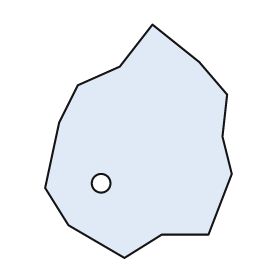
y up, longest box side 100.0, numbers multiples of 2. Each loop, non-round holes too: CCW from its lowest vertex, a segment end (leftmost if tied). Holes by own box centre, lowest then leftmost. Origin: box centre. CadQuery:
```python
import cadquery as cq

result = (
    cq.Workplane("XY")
    .moveTo(-6.0, -50.0)
    .lineTo(10.0, -40.0)
    .lineTo(30.0, -40.0)
    .lineTo(40.0, -14.0)
    .lineTo(36.0, 2.0)
    .lineTo(38.0, 20.0)
    .lineTo(26.0, 34.0)
    .lineTo(6.0, 50.0)
    .lineTo(-8.0, 32.0)
    .lineTo(-26.0, 24.0)
    .lineTo(-34.0, 8.0)
    .lineTo(-40.0, -20.0)
    .lineTo(-30.0, -36.0)
    .close()
    .moveTo(-16.0, -18.0)
    .circle(4.0)
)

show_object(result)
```